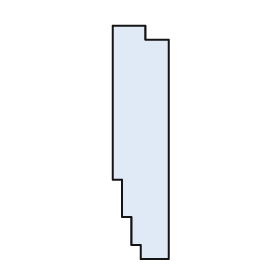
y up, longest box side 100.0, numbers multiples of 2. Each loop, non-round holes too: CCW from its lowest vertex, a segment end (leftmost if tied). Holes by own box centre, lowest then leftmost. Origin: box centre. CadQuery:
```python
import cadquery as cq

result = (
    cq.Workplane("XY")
    .moveTo(0.0, -50.0)
    .lineTo(12.0, -50.0)
    .lineTo(12.0, 44.0)
    .lineTo(2.0, 44.0)
    .lineTo(2.0, 50.0)
    .lineTo(-12.0, 50.0)
    .lineTo(-12.0, -16.0)
    .lineTo(-8.0, -16.0)
    .lineTo(-8.0, -32.0)
    .lineTo(-4.0, -32.0)
    .lineTo(-4.0, -44.0)
    .lineTo(0.0, -44.0)
    .close()
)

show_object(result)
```